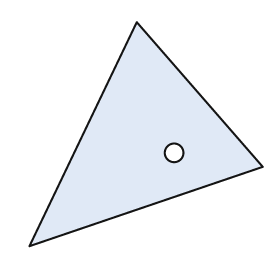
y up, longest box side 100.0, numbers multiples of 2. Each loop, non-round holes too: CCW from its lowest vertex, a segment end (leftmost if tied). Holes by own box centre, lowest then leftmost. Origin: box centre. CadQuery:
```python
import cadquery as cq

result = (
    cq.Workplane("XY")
    .moveTo(-50.0, -48.0)
    .lineTo(50.0, -14.0)
    .lineTo(-4.0, 48.0)
    .close()
    .moveTo(12.0, -8.0)
    .circle(4.0)
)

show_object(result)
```